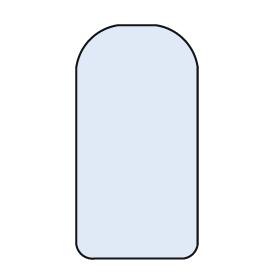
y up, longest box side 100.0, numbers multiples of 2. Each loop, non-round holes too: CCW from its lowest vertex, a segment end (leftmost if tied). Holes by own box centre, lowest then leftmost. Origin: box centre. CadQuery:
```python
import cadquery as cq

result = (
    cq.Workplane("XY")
    .moveTo(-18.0, -50.0)
    .lineTo(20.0, -50.0)
    .threePointArc((24.0, -48.0), (26.0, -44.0))
    .lineTo(26.0, 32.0)
    .threePointArc((20.0, 44.0), (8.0, 50.0))
    .lineTo(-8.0, 50.0)
    .threePointArc((-20.0, 44.0), (-26.0, 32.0))
    .lineTo(-26.0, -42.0)
    .threePointArc((-24.0, -48.0), (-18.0, -50.0))
    .close()
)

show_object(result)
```